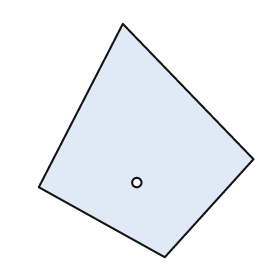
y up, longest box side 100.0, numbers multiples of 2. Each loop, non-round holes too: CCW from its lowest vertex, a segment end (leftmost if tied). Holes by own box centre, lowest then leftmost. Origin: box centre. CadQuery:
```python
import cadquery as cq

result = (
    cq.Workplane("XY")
    .moveTo(8.0, -50.0)
    .lineTo(46.0, -8.0)
    .lineTo(-10.0, 50.0)
    .lineTo(-46.0, -20.0)
    .close()
    .moveTo(-4.0, -18.0)
    .circle(2.0)
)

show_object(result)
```